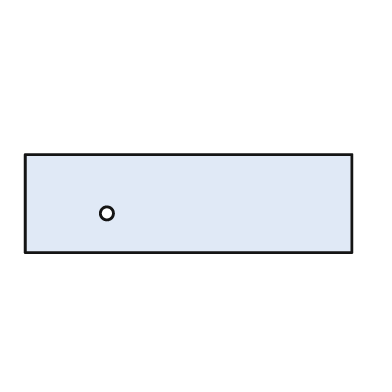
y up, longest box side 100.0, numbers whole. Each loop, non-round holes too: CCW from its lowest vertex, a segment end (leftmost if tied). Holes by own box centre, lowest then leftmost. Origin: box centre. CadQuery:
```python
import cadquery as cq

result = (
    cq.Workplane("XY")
    .moveTo(-50.0, -15.0)
    .lineTo(50.0, -15.0)
    .lineTo(50.0, 15.0)
    .lineTo(-50.0, 15.0)
    .close()
    .moveTo(-25.0, -3.0)
    .circle(2.0)
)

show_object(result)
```